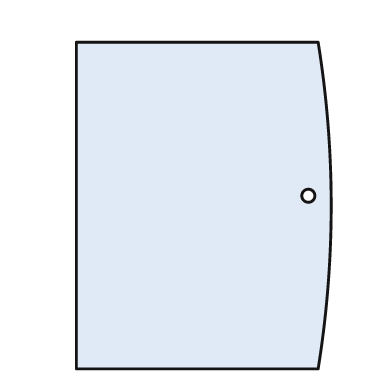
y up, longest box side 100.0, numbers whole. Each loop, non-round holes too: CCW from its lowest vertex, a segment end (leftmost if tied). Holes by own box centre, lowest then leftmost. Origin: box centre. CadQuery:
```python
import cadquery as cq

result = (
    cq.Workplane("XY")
    .moveTo(-39.0, -50.0)
    .lineTo(35.0, -50.0)
    .threePointArc((39.0, 0.0), (35.0, 50.0))
    .lineTo(-39.0, 50.0)
    .close()
    .moveTo(32.0, 3.0)
    .circle(2.0)
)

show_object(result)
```